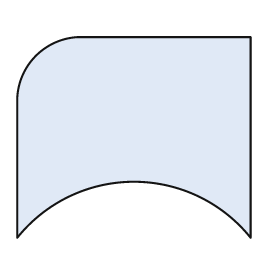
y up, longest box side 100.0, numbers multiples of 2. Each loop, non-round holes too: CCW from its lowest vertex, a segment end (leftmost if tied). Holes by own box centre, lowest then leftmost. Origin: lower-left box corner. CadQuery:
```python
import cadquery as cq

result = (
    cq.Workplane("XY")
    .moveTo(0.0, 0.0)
    .threePointArc((50.0, 24.0), (100.0, 0.0))
    .lineTo(100.0, 86.0)
    .lineTo(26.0, 86.0)
    .threePointArc((8.0, 78.0), (0.0, 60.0))
    .close()
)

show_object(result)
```